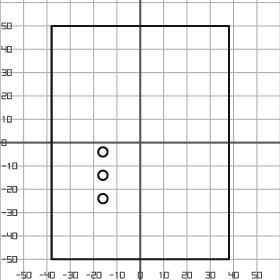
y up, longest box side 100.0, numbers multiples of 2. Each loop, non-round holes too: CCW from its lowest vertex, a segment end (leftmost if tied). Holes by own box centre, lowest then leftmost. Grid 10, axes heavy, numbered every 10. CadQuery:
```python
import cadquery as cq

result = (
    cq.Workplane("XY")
    .moveTo(-38.0, -50.0)
    .lineTo(38.0, -50.0)
    .lineTo(38.0, 50.0)
    .lineTo(-38.0, 50.0)
    .close()
    .moveTo(-16.0, -24.0)
    .circle(2.0)
    .moveTo(-16.0, -14.0)
    .circle(2.0)
    .moveTo(-16.0, -4.0)
    .circle(2.0)
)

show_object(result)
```